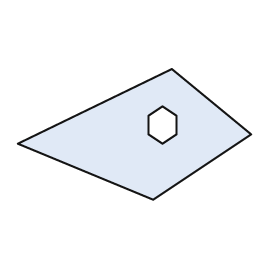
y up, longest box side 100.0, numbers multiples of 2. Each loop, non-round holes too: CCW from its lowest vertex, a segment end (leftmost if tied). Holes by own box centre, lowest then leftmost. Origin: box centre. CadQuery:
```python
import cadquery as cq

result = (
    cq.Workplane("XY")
    .moveTo(8.0, -28.0)
    .lineTo(50.0, 0.0)
    .lineTo(16.0, 28.0)
    .lineTo(-50.0, -4.0)
    .close()
    .moveTo(12.0, -4.0)
    .lineTo(18.0, 0.0)
    .lineTo(18.0, 8.0)
    .lineTo(12.0, 12.0)
    .lineTo(6.0, 8.0)
    .lineTo(6.0, 0.0)
    .close()
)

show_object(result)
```